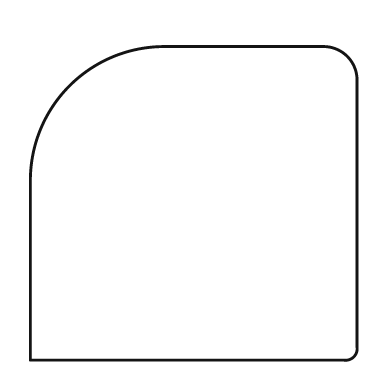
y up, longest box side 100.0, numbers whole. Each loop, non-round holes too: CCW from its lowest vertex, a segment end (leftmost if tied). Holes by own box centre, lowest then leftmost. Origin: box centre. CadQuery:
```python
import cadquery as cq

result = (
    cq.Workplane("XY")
    .moveTo(-50.0, -48.0)
    .lineTo(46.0, -48.0)
    .threePointArc((49.0, -47.0), (50.0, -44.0))
    .lineTo(50.0, 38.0)
    .threePointArc((47.0, 45.0), (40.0, 48.0))
    .lineTo(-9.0, 48.0)
    .threePointArc((-38.0, 36.0), (-50.0, 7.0))
    .close()
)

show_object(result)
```